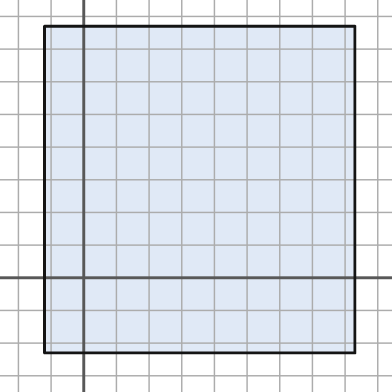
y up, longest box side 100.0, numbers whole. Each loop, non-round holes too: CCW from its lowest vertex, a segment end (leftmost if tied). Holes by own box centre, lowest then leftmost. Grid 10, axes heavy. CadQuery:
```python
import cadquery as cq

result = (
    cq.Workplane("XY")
    .moveTo(-12.0, -23.0)
    .lineTo(83.0, -23.0)
    .lineTo(83.0, 77.0)
    .lineTo(-12.0, 77.0)
    .close()
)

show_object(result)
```